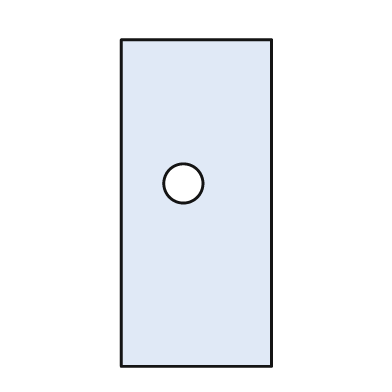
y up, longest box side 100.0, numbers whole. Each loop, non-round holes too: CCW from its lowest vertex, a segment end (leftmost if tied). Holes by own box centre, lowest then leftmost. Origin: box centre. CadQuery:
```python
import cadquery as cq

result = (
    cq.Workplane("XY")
    .moveTo(-23.0, -50.0)
    .lineTo(23.0, -50.0)
    .lineTo(23.0, 50.0)
    .lineTo(-23.0, 50.0)
    .close()
    .moveTo(-4.0, 6.0)
    .circle(6.0)
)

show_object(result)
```